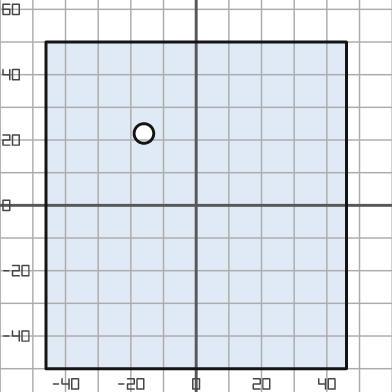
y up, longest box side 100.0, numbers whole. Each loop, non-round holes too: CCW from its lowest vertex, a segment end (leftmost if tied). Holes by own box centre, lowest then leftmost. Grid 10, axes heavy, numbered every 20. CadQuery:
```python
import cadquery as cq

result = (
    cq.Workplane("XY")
    .moveTo(-46.0, -50.0)
    .lineTo(46.0, -50.0)
    .lineTo(46.0, 50.0)
    .lineTo(-46.0, 50.0)
    .close()
    .moveTo(-16.0, 22.0)
    .circle(3.0)
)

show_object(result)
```